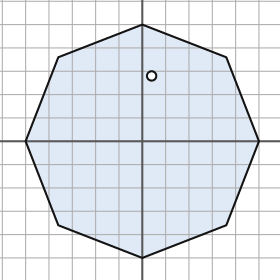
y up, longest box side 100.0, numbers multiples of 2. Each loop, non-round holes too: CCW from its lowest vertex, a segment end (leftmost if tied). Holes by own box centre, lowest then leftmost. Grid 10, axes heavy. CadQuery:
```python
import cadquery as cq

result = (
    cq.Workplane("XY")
    .moveTo(0.0, -50.0)
    .lineTo(36.0, -36.0)
    .lineTo(50.0, 0.0)
    .lineTo(36.0, 36.0)
    .lineTo(0.0, 50.0)
    .lineTo(-36.0, 36.0)
    .lineTo(-50.0, 0.0)
    .lineTo(-36.0, -36.0)
    .close()
    .moveTo(4.0, 28.0)
    .circle(2.0)
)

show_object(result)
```